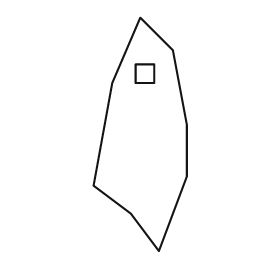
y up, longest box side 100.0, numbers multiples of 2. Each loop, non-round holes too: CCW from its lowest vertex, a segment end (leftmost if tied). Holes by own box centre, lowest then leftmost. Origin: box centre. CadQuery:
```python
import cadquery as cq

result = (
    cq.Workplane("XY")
    .moveTo(8.0, -50.0)
    .lineTo(20.0, -18.0)
    .lineTo(20.0, 4.0)
    .lineTo(14.0, 36.0)
    .lineTo(0.0, 50.0)
    .lineTo(-12.0, 22.0)
    .lineTo(-20.0, -22.0)
    .lineTo(-4.0, -34.0)
    .close()
    .moveTo(-2.0, 22.0)
    .lineTo(6.0, 22.0)
    .lineTo(6.0, 30.0)
    .lineTo(-2.0, 30.0)
    .close()
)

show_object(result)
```